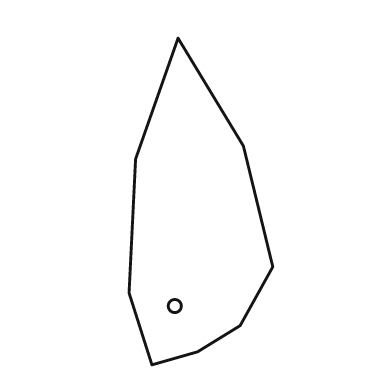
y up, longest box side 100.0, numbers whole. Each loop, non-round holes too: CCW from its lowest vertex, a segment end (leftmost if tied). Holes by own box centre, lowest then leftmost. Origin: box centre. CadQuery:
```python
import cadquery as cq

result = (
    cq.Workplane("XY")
    .moveTo(-15.0, -50.0)
    .lineTo(-1.0, -46.0)
    .lineTo(12.0, -38.0)
    .lineTo(22.0, -20.0)
    .lineTo(13.0, 17.0)
    .lineTo(-7.0, 50.0)
    .lineTo(-20.0, 13.0)
    .lineTo(-22.0, -28.0)
    .close()
    .moveTo(-8.0, -32.0)
    .circle(2.0)
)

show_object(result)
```